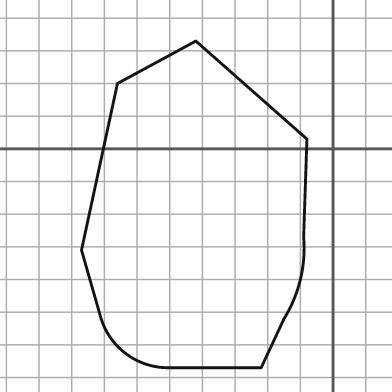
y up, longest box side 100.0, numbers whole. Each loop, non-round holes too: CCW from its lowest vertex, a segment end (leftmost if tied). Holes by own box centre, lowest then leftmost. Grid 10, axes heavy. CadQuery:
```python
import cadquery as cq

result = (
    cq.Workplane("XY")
    .moveTo(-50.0, -67.0)
    .lineTo(-22.0, -67.0)
    .lineTo(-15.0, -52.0)
    .threePointArc((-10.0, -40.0), (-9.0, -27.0))
    .lineTo(-8.0, 3.0)
    .lineTo(-42.0, 33.0)
    .lineTo(-66.0, 20.0)
    .lineTo(-77.0, -31.0)
    .lineTo(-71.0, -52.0)
    .threePointArc((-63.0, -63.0), (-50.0, -67.0))
    .close()
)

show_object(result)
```